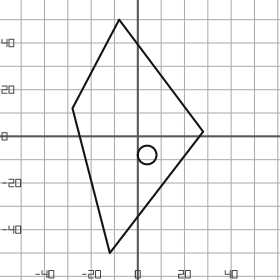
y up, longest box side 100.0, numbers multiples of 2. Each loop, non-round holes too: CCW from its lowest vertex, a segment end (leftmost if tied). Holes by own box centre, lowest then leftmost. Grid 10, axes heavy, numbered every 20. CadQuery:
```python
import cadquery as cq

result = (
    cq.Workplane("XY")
    .moveTo(-12.0, -50.0)
    .lineTo(28.0, 2.0)
    .lineTo(-8.0, 50.0)
    .lineTo(-28.0, 12.0)
    .close()
    .moveTo(4.0, -8.0)
    .circle(4.0)
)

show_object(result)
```